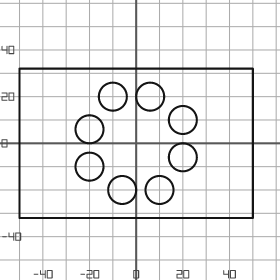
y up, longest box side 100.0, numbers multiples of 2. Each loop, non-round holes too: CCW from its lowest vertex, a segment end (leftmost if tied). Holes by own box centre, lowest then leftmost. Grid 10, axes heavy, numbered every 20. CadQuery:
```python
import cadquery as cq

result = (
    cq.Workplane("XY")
    .moveTo(-50.0, -32.0)
    .lineTo(50.0, -32.0)
    .lineTo(50.0, 32.0)
    .lineTo(-50.0, 32.0)
    .close()
    .moveTo(-6.0, -20.0)
    .circle(6.0)
    .moveTo(10.0, -20.0)
    .circle(6.0)
    .moveTo(-20.0, -10.0)
    .circle(6.0)
    .moveTo(20.0, -6.0)
    .circle(6.0)
    .moveTo(-20.0, 6.0)
    .circle(6.0)
    .moveTo(20.0, 10.0)
    .circle(6.0)
    .moveTo(-10.0, 20.0)
    .circle(6.0)
    .moveTo(6.0, 20.0)
    .circle(6.0)
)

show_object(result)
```